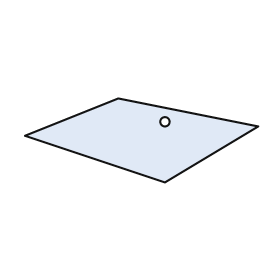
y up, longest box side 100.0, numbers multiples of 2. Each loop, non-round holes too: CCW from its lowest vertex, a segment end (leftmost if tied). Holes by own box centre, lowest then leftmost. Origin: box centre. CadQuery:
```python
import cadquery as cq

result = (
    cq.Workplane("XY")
    .moveTo(10.0, -18.0)
    .lineTo(50.0, 6.0)
    .lineTo(-10.0, 18.0)
    .lineTo(-50.0, 2.0)
    .close()
    .moveTo(10.0, 8.0)
    .circle(2.0)
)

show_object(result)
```